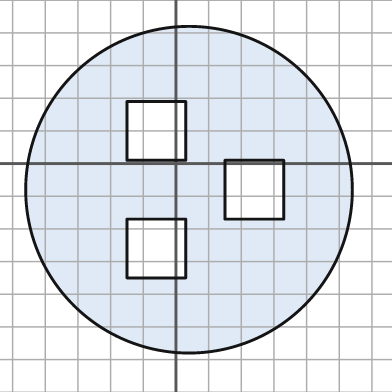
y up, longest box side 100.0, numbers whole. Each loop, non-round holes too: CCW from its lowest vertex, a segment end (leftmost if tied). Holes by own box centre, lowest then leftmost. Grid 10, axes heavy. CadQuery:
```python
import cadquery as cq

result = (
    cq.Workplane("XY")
    .moveTo(4.0, -8.0)
    .circle(50.0)
    .moveTo(-15.0, -35.0)
    .lineTo(3.0, -35.0)
    .lineTo(3.0, -17.0)
    .lineTo(-15.0, -17.0)
    .close()
    .moveTo(15.0, -17.0)
    .lineTo(33.0, -17.0)
    .lineTo(33.0, 1.0)
    .lineTo(15.0, 1.0)
    .close()
    .moveTo(-15.0, 1.0)
    .lineTo(3.0, 1.0)
    .lineTo(3.0, 19.0)
    .lineTo(-15.0, 19.0)
    .close()
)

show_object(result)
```